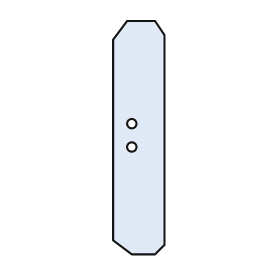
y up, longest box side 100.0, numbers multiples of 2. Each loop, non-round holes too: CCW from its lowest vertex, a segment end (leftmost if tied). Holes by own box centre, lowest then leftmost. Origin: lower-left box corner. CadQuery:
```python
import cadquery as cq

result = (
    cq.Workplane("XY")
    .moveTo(8.0, 0.0)
    .lineTo(18.0, 0.0)
    .lineTo(22.0, 4.0)
    .lineTo(22.0, 94.0)
    .lineTo(18.0, 100.0)
    .lineTo(6.0, 100.0)
    .lineTo(0.0, 92.0)
    .lineTo(0.0, 6.0)
    .close()
    .moveTo(8.0, 46.0)
    .circle(2.0)
    .moveTo(8.0, 56.0)
    .circle(2.0)
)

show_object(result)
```